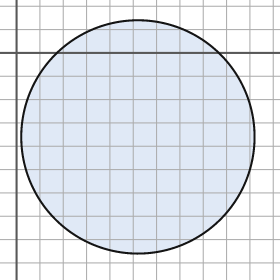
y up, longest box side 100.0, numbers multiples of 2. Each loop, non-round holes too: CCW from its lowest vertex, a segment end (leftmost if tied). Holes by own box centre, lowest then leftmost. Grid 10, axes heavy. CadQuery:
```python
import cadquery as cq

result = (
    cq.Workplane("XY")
    .moveTo(52.0, -36.0)
    .circle(50.0)
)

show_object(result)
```